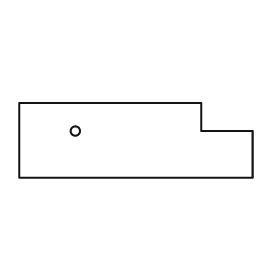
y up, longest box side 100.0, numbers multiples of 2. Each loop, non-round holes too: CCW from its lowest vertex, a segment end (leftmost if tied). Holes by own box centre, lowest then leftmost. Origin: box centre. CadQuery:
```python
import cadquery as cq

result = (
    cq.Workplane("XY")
    .moveTo(-50.0, -16.0)
    .lineTo(50.0, -16.0)
    .lineTo(50.0, 4.0)
    .lineTo(28.0, 4.0)
    .lineTo(28.0, 16.0)
    .lineTo(-50.0, 16.0)
    .close()
    .moveTo(-26.0, 4.0)
    .circle(2.0)
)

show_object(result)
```